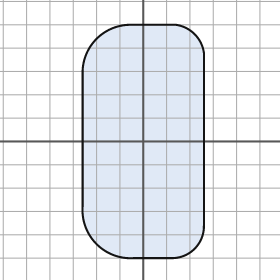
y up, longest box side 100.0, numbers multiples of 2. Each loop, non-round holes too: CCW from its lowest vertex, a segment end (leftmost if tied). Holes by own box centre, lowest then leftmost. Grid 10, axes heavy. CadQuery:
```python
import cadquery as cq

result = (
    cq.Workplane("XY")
    .moveTo(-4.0, -50.0)
    .lineTo(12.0, -50.0)
    .threePointArc((22.0, -46.0), (26.0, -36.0))
    .lineTo(26.0, 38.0)
    .threePointArc((22.0, 46.0), (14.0, 50.0))
    .lineTo(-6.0, 50.0)
    .threePointArc((-20.0, 44.0), (-26.0, 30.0))
    .lineTo(-26.0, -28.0)
    .threePointArc((-20.0, -44.0), (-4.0, -50.0))
    .close()
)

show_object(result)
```